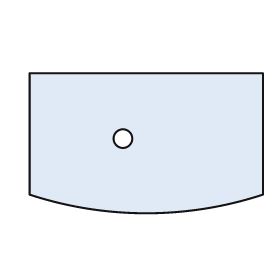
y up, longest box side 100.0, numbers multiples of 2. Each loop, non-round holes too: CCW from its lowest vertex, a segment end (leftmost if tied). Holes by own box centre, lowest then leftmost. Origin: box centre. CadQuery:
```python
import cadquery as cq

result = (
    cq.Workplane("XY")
    .moveTo(-50.0, -22.0)
    .threePointArc((0.0, -30.0), (50.0, -22.0))
    .lineTo(50.0, 30.0)
    .lineTo(-50.0, 30.0)
    .close()
    .moveTo(-10.0, 2.0)
    .circle(4.0)
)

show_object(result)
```